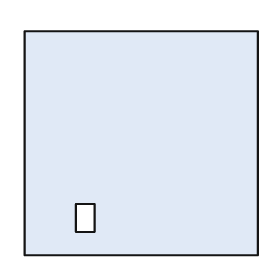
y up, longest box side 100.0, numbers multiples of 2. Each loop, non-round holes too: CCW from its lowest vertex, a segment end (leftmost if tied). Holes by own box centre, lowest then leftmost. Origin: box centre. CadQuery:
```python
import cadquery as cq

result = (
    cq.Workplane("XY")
    .moveTo(-50.0, -48.0)
    .lineTo(50.0, -48.0)
    .lineTo(50.0, 48.0)
    .lineTo(-50.0, 48.0)
    .close()
    .moveTo(-28.0, -38.0)
    .lineTo(-20.0, -38.0)
    .lineTo(-20.0, -26.0)
    .lineTo(-28.0, -26.0)
    .close()
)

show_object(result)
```